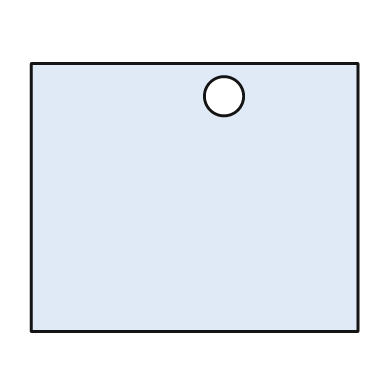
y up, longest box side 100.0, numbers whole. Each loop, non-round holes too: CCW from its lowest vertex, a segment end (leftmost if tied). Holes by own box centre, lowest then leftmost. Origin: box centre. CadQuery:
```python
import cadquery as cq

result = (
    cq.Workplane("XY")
    .moveTo(-50.0, -41.0)
    .lineTo(50.0, -41.0)
    .lineTo(50.0, 41.0)
    .lineTo(-50.0, 41.0)
    .close()
    .moveTo(9.0, 31.0)
    .circle(6.0)
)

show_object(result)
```